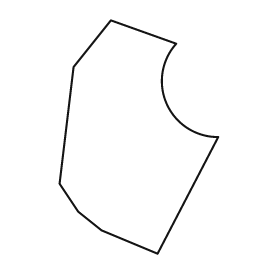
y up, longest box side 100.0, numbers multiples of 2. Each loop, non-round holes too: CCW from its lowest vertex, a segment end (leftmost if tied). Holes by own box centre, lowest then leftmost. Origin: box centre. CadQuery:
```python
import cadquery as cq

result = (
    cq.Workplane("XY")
    .moveTo(8.0, -50.0)
    .lineTo(34.0, 0.0)
    .threePointArc((12.0, 14.0), (16.0, 40.0))
    .lineTo(-12.0, 50.0)
    .lineTo(-28.0, 30.0)
    .lineTo(-34.0, -20.0)
    .lineTo(-26.0, -32.0)
    .lineTo(-16.0, -40.0)
    .close()
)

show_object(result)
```